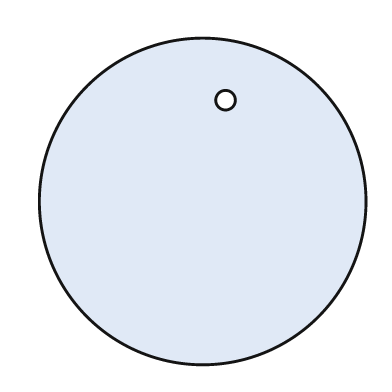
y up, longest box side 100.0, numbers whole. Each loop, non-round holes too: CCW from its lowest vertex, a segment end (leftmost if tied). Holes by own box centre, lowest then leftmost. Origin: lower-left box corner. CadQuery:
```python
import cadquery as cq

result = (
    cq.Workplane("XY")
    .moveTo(50.0, 50.0)
    .circle(50.0)
    .moveTo(57.0, 81.0)
    .circle(3.0)
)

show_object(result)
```